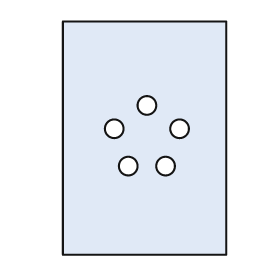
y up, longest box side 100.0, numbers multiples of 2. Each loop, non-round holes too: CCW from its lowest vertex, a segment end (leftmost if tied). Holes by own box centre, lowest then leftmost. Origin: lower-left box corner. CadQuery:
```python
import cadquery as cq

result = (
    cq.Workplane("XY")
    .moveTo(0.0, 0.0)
    .lineTo(70.0, 0.0)
    .lineTo(70.0, 100.0)
    .lineTo(0.0, 100.0)
    .close()
    .moveTo(28.0, 38.0)
    .circle(4.0)
    .moveTo(44.0, 38.0)
    .circle(4.0)
    .moveTo(22.0, 54.0)
    .circle(4.0)
    .moveTo(50.0, 54.0)
    .circle(4.0)
    .moveTo(36.0, 64.0)
    .circle(4.0)
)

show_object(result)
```